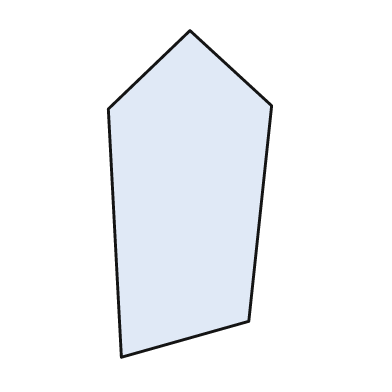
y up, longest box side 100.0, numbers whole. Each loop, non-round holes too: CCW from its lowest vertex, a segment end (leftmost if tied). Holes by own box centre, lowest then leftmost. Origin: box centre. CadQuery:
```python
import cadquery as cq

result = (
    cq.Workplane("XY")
    .moveTo(-21.0, -50.0)
    .lineTo(18.0, -39.0)
    .lineTo(25.0, 27.0)
    .lineTo(0.0, 50.0)
    .lineTo(-25.0, 26.0)
    .close()
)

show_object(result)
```